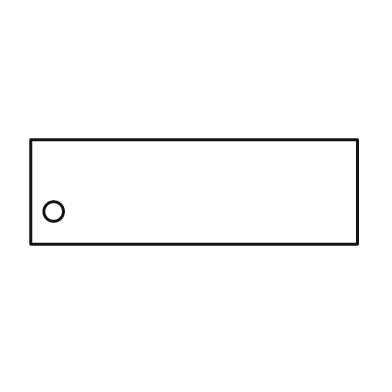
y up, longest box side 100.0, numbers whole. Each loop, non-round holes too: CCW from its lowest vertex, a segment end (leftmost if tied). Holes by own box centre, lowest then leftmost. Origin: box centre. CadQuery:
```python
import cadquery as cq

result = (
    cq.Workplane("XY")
    .moveTo(-50.0, -16.0)
    .lineTo(50.0, -16.0)
    .lineTo(50.0, 16.0)
    .lineTo(-50.0, 16.0)
    .close()
    .moveTo(-43.0, -6.0)
    .circle(3.0)
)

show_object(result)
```